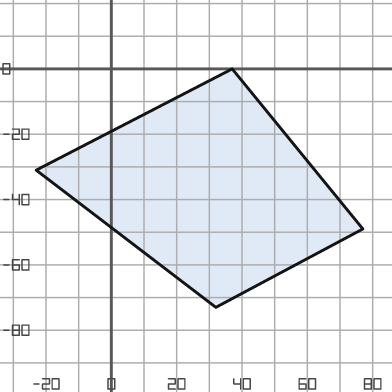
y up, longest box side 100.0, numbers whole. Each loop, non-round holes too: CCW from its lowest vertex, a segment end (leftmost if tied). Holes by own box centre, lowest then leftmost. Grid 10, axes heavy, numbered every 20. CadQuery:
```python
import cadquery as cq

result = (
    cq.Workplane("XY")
    .moveTo(32.0, -73.0)
    .lineTo(77.0, -49.0)
    .lineTo(37.0, 0.0)
    .lineTo(-23.0, -31.0)
    .close()
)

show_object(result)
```